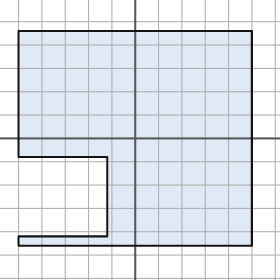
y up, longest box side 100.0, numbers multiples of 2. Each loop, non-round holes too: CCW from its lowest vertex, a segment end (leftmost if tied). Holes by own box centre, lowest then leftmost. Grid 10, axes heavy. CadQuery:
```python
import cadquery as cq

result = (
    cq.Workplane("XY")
    .moveTo(-50.0, -46.0)
    .lineTo(50.0, -46.0)
    .lineTo(50.0, 46.0)
    .lineTo(-50.0, 46.0)
    .lineTo(-50.0, -8.0)
    .lineTo(-12.0, -8.0)
    .lineTo(-12.0, -42.0)
    .lineTo(-50.0, -42.0)
    .close()
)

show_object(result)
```